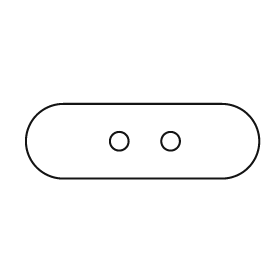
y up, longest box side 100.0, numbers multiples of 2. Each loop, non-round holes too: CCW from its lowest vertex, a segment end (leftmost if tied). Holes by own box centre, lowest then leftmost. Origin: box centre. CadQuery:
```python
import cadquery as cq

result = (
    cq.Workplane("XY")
    .moveTo(-34.0, -16.0)
    .lineTo(34.0, -16.0)
    .threePointArc((50.0, 0.0), (34.0, 16.0))
    .lineTo(-34.0, 16.0)
    .threePointArc((-50.0, 0.0), (-34.0, -16.0))
    .close()
    .moveTo(-10.0, 0.0)
    .circle(4.0)
    .moveTo(12.0, 0.0)
    .circle(4.0)
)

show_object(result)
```